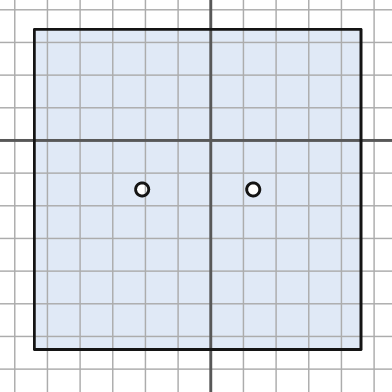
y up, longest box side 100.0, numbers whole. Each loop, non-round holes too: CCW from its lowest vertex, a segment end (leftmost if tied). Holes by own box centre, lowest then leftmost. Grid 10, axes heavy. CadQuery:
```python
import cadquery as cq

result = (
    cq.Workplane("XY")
    .moveTo(-54.0, -64.0)
    .lineTo(46.0, -64.0)
    .lineTo(46.0, 34.0)
    .lineTo(-54.0, 34.0)
    .close()
    .moveTo(-21.0, -15.0)
    .circle(2.0)
    .moveTo(13.0, -15.0)
    .circle(2.0)
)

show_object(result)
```